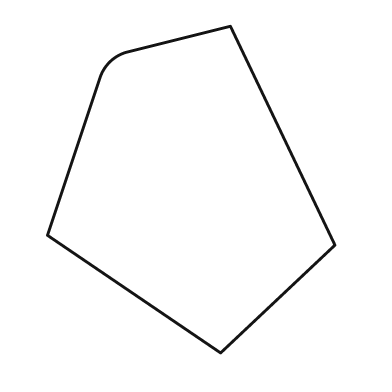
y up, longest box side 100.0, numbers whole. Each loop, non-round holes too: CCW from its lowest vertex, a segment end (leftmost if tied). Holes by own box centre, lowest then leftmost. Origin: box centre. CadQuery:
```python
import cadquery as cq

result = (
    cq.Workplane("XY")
    .moveTo(9.0, -50.0)
    .lineTo(44.0, -17.0)
    .lineTo(12.0, 50.0)
    .lineTo(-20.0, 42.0)
    .threePointArc((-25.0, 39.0), (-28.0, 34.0))
    .lineTo(-44.0, -14.0)
    .close()
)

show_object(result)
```